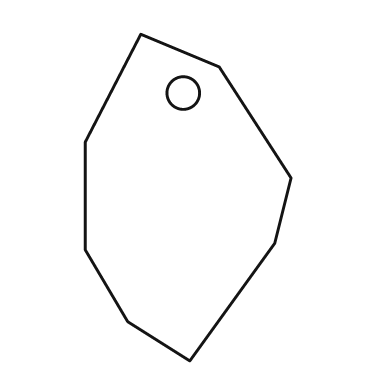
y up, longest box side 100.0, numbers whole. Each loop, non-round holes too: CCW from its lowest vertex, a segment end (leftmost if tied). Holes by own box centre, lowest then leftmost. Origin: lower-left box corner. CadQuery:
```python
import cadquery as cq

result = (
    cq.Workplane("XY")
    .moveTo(32.0, 0.0)
    .lineTo(58.0, 36.0)
    .lineTo(63.0, 56.0)
    .lineTo(41.0, 90.0)
    .lineTo(17.0, 100.0)
    .lineTo(0.0, 67.0)
    .lineTo(0.0, 34.0)
    .lineTo(13.0, 12.0)
    .close()
    .moveTo(30.0, 82.0)
    .circle(5.0)
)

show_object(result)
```